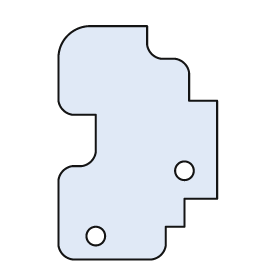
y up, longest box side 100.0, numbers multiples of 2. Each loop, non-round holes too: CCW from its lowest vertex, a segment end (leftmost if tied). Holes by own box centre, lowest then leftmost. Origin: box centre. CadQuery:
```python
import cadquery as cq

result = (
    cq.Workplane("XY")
    .moveTo(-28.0, -50.0)
    .lineTo(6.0, -50.0)
    .threePointArc((10.0, -48.0), (12.0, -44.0))
    .lineTo(12.0, -36.0)
    .lineTo(20.0, -36.0)
    .lineTo(20.0, -24.0)
    .lineTo(34.0, -24.0)
    .lineTo(34.0, 18.0)
    .lineTo(22.0, 18.0)
    .lineTo(22.0, 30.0)
    .threePointArc((20.0, 34.0), (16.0, 36.0))
    .lineTo(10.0, 36.0)
    .threePointArc((6.0, 38.0), (4.0, 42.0))
    .lineTo(4.0, 50.0)
    .lineTo(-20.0, 50.0)
    .threePointArc((-30.0, 46.0), (-34.0, 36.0))
    .lineTo(-34.0, 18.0)
    .threePointArc((-32.0, 14.0), (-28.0, 12.0))
    .lineTo(-18.0, 12.0)
    .lineTo(-18.0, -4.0)
    .threePointArc((-20.0, -8.0), (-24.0, -10.0))
    .lineTo(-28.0, -10.0)
    .threePointArc((-32.0, -12.0), (-34.0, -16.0))
    .lineTo(-34.0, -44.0)
    .threePointArc((-32.0, -48.0), (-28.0, -50.0))
    .close()
    .moveTo(-18.0, -40.0)
    .circle(4.0)
    .moveTo(20.0, -12.0)
    .circle(4.0)
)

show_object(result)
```